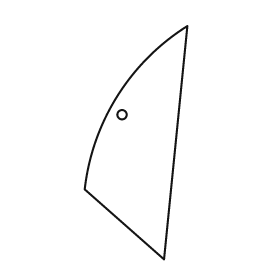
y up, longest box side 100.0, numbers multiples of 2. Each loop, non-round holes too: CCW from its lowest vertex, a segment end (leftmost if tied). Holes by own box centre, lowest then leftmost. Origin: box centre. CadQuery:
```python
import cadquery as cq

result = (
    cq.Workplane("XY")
    .moveTo(12.0, -50.0)
    .lineTo(22.0, 50.0)
    .threePointArc((-8.0, 20.0), (-22.0, -20.0))
    .close()
    .moveTo(-6.0, 12.0)
    .circle(2.0)
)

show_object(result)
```